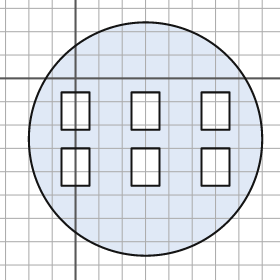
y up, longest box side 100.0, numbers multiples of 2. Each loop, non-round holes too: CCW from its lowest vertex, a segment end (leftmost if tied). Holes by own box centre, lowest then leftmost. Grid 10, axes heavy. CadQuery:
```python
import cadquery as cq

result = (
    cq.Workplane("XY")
    .moveTo(30.0, -26.0)
    .circle(50.0)
    .moveTo(-6.0, -46.0)
    .lineTo(6.0, -46.0)
    .lineTo(6.0, -30.0)
    .lineTo(-6.0, -30.0)
    .close()
    .moveTo(24.0, -46.0)
    .lineTo(36.0, -46.0)
    .lineTo(36.0, -30.0)
    .lineTo(24.0, -30.0)
    .close()
    .moveTo(54.0, -46.0)
    .lineTo(66.0, -46.0)
    .lineTo(66.0, -30.0)
    .lineTo(54.0, -30.0)
    .close()
    .moveTo(-6.0, -22.0)
    .lineTo(6.0, -22.0)
    .lineTo(6.0, -6.0)
    .lineTo(-6.0, -6.0)
    .close()
    .moveTo(24.0, -22.0)
    .lineTo(36.0, -22.0)
    .lineTo(36.0, -6.0)
    .lineTo(24.0, -6.0)
    .close()
    .moveTo(54.0, -22.0)
    .lineTo(66.0, -22.0)
    .lineTo(66.0, -6.0)
    .lineTo(54.0, -6.0)
    .close()
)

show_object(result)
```